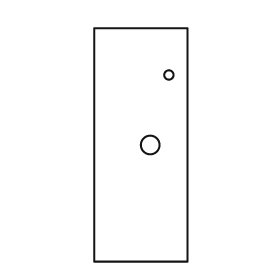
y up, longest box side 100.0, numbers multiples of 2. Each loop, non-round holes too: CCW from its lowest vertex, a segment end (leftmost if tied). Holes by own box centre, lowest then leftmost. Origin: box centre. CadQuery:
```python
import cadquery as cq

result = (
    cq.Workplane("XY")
    .moveTo(-20.0, -50.0)
    .lineTo(20.0, -50.0)
    .lineTo(20.0, 50.0)
    .lineTo(-20.0, 50.0)
    .close()
    .moveTo(4.0, 0.0)
    .circle(4.0)
    .moveTo(12.0, 30.0)
    .circle(2.0)
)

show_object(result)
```